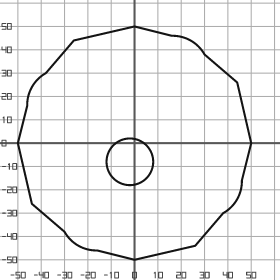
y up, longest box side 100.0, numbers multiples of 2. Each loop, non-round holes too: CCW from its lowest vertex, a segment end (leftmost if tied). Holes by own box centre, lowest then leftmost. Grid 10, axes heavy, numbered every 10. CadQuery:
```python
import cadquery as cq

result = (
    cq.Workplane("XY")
    .moveTo(0.0, -50.0)
    .lineTo(26.0, -44.0)
    .lineTo(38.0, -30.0)
    .threePointArc((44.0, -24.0), (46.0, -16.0))
    .lineTo(50.0, 0.0)
    .lineTo(44.0, 26.0)
    .lineTo(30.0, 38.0)
    .threePointArc((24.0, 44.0), (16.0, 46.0))
    .lineTo(0.0, 50.0)
    .lineTo(-26.0, 44.0)
    .lineTo(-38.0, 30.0)
    .threePointArc((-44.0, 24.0), (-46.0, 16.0))
    .lineTo(-50.0, 0.0)
    .lineTo(-44.0, -26.0)
    .lineTo(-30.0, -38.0)
    .threePointArc((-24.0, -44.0), (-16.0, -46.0))
    .close()
    .moveTo(-2.0, -8.0)
    .circle(10.0)
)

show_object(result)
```